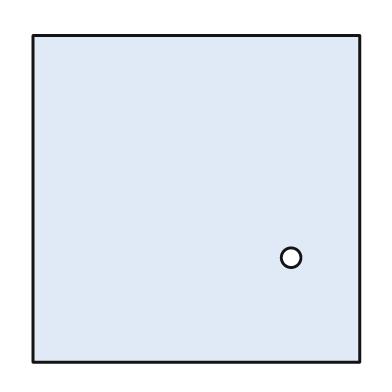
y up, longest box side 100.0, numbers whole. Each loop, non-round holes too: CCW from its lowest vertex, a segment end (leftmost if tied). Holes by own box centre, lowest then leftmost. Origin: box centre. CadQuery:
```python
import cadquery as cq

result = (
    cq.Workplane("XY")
    .moveTo(-50.0, -50.0)
    .lineTo(50.0, -50.0)
    .lineTo(50.0, 50.0)
    .lineTo(-50.0, 50.0)
    .close()
    .moveTo(29.0, -18.0)
    .circle(3.0)
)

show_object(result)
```